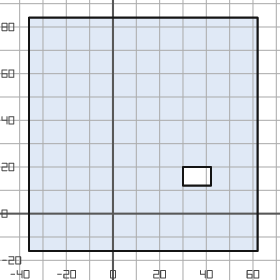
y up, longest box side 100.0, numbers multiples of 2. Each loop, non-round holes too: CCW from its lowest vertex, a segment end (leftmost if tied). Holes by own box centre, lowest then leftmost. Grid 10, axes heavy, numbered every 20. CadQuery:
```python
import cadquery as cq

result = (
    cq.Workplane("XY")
    .moveTo(-36.0, -16.0)
    .lineTo(62.0, -16.0)
    .lineTo(62.0, 84.0)
    .lineTo(-36.0, 84.0)
    .close()
    .moveTo(30.0, 12.0)
    .lineTo(42.0, 12.0)
    .lineTo(42.0, 20.0)
    .lineTo(30.0, 20.0)
    .close()
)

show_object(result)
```